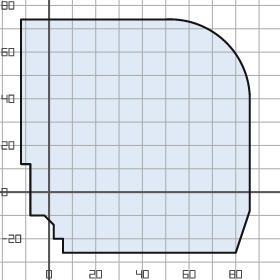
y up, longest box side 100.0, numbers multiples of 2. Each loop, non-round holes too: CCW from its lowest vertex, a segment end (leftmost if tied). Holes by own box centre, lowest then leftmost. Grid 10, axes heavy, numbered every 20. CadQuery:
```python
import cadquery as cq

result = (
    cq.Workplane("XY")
    .moveTo(6.0, -26.0)
    .lineTo(80.0, -26.0)
    .lineTo(86.0, -8.0)
    .lineTo(86.0, 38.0)
    .threePointArc((76.0, 64.0), (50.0, 74.0))
    .lineTo(-12.0, 74.0)
    .lineTo(-12.0, 12.0)
    .lineTo(-8.0, 12.0)
    .lineTo(-8.0, -10.0)
    .lineTo(-2.0, -10.0)
    .lineTo(2.0, -14.0)
    .lineTo(2.0, -20.0)
    .lineTo(6.0, -20.0)
    .close()
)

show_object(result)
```